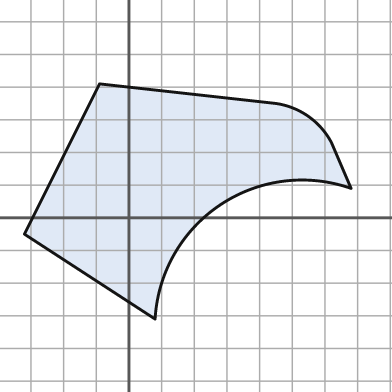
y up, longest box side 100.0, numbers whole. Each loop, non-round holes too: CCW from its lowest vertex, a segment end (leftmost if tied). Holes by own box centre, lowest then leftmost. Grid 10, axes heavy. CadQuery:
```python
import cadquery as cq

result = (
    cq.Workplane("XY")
    .moveTo(8.0, -31.0)
    .threePointArc((28.0, 4.0), (68.0, 9.0))
    .lineTo(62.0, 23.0)
    .threePointArc((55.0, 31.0), (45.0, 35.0))
    .lineTo(-9.0, 41.0)
    .lineTo(-32.0, -5.0)
    .close()
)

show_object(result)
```